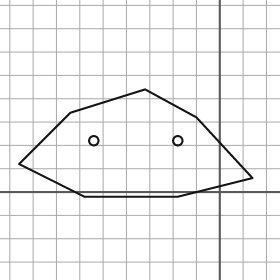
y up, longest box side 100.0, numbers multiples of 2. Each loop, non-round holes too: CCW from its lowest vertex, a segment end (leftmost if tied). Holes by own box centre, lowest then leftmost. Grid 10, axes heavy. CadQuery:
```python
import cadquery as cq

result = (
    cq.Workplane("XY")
    .moveTo(-58.0, -2.0)
    .lineTo(-18.0, -2.0)
    .lineTo(14.0, 6.0)
    .lineTo(-10.0, 32.0)
    .lineTo(-32.0, 44.0)
    .lineTo(-64.0, 34.0)
    .lineTo(-86.0, 12.0)
    .close()
    .moveTo(-54.0, 22.0)
    .circle(2.0)
    .moveTo(-18.0, 22.0)
    .circle(2.0)
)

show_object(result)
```